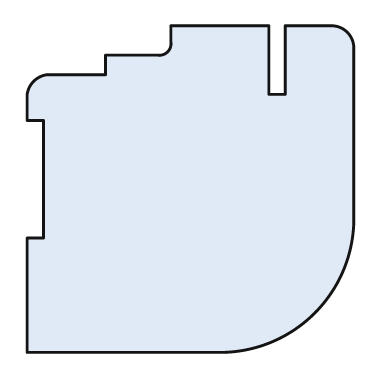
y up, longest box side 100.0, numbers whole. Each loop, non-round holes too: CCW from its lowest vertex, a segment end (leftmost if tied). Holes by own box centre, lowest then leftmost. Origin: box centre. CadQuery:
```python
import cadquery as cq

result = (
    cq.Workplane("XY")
    .moveTo(-50.0, -50.0)
    .lineTo(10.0, -50.0)
    .threePointArc((38.0, -38.0), (50.0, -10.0))
    .lineTo(50.0, 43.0)
    .threePointArc((48.0, 48.0), (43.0, 50.0))
    .lineTo(29.0, 50.0)
    .lineTo(29.0, 29.0)
    .lineTo(24.0, 29.0)
    .lineTo(24.0, 50.0)
    .lineTo(-6.0, 50.0)
    .lineTo(-6.0, 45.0)
    .threePointArc((-7.0, 42.0), (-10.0, 41.0))
    .lineTo(-26.0, 41.0)
    .lineTo(-26.0, 35.0)
    .lineTo(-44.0, 35.0)
    .threePointArc((-48.0, 33.0), (-50.0, 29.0))
    .lineTo(-50.0, 21.0)
    .lineTo(-45.0, 21.0)
    .lineTo(-45.0, -15.0)
    .lineTo(-50.0, -15.0)
    .close()
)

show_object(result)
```